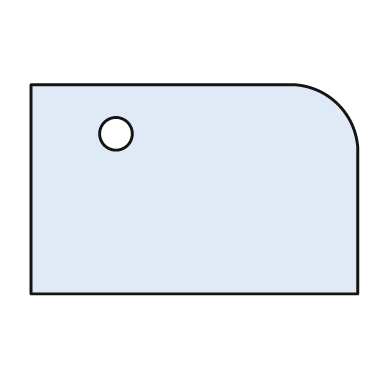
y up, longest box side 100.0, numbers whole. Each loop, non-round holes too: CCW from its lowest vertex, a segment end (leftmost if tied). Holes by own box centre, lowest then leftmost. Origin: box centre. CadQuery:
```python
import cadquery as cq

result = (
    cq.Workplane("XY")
    .moveTo(-50.0, -32.0)
    .lineTo(50.0, -32.0)
    .lineTo(50.0, 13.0)
    .threePointArc((44.0, 26.0), (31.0, 32.0))
    .lineTo(-50.0, 32.0)
    .close()
    .moveTo(-24.0, 17.0)
    .circle(5.0)
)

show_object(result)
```